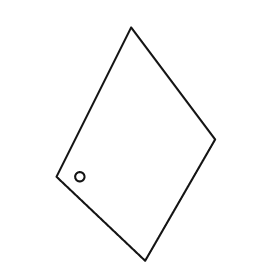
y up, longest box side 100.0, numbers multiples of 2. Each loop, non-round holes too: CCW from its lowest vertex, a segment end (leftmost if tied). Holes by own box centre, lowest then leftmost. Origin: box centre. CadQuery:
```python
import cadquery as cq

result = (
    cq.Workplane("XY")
    .moveTo(4.0, -50.0)
    .lineTo(34.0, 2.0)
    .lineTo(-2.0, 50.0)
    .lineTo(-34.0, -14.0)
    .close()
    .moveTo(-24.0, -14.0)
    .circle(2.0)
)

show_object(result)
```